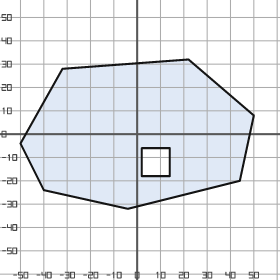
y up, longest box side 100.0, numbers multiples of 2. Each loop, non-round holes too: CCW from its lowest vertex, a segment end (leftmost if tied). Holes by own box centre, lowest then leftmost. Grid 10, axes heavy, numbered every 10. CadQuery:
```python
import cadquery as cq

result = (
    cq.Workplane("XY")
    .moveTo(-4.0, -32.0)
    .lineTo(44.0, -20.0)
    .lineTo(50.0, 8.0)
    .lineTo(22.0, 32.0)
    .lineTo(-32.0, 28.0)
    .lineTo(-50.0, -4.0)
    .lineTo(-40.0, -24.0)
    .close()
    .moveTo(2.0, -18.0)
    .lineTo(14.0, -18.0)
    .lineTo(14.0, -6.0)
    .lineTo(2.0, -6.0)
    .close()
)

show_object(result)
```